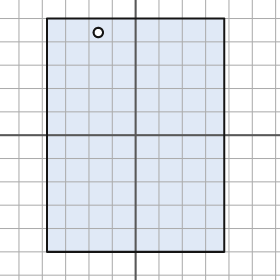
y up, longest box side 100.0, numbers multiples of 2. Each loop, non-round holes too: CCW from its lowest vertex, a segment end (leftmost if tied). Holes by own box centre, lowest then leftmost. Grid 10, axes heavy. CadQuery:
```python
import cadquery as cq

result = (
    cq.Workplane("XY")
    .moveTo(-38.0, -50.0)
    .lineTo(38.0, -50.0)
    .lineTo(38.0, 50.0)
    .lineTo(-38.0, 50.0)
    .close()
    .moveTo(-16.0, 44.0)
    .circle(2.0)
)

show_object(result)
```